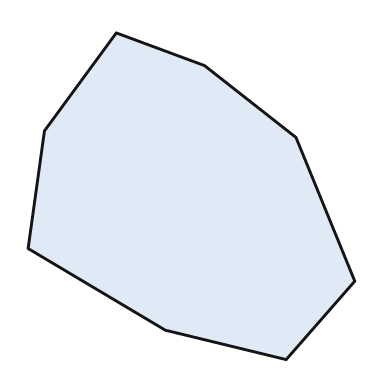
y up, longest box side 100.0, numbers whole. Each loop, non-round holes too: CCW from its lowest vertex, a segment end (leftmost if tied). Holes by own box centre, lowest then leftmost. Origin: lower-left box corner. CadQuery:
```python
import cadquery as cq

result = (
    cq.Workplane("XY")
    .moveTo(79.0, 0.0)
    .lineTo(100.0, 24.0)
    .lineTo(82.0, 68.0)
    .lineTo(54.0, 90.0)
    .lineTo(27.0, 100.0)
    .lineTo(5.0, 70.0)
    .lineTo(0.0, 34.0)
    .lineTo(42.0, 9.0)
    .close()
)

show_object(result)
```